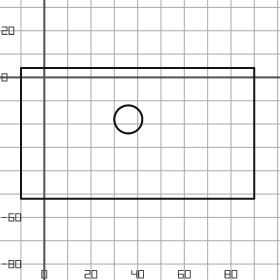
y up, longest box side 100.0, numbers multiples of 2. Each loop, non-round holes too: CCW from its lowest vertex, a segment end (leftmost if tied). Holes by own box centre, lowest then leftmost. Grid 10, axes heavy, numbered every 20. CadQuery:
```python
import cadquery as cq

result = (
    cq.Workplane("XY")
    .moveTo(-10.0, -52.0)
    .lineTo(90.0, -52.0)
    .lineTo(90.0, 4.0)
    .lineTo(-10.0, 4.0)
    .close()
    .moveTo(36.0, -18.0)
    .circle(6.0)
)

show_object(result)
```